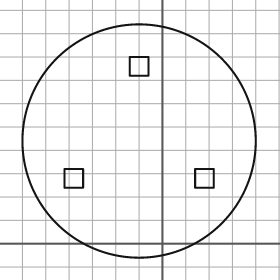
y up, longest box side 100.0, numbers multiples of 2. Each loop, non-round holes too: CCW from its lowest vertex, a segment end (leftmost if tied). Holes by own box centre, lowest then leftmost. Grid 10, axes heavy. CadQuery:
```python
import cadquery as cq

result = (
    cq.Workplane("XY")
    .moveTo(-10.0, 44.0)
    .circle(50.0)
    .moveTo(-42.0, 24.0)
    .lineTo(-34.0, 24.0)
    .lineTo(-34.0, 32.0)
    .lineTo(-42.0, 32.0)
    .close()
    .moveTo(14.0, 24.0)
    .lineTo(22.0, 24.0)
    .lineTo(22.0, 32.0)
    .lineTo(14.0, 32.0)
    .close()
    .moveTo(-14.0, 72.0)
    .lineTo(-6.0, 72.0)
    .lineTo(-6.0, 80.0)
    .lineTo(-14.0, 80.0)
    .close()
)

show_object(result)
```